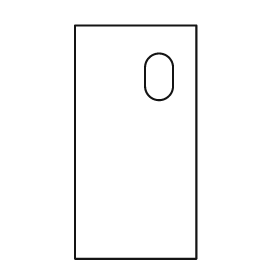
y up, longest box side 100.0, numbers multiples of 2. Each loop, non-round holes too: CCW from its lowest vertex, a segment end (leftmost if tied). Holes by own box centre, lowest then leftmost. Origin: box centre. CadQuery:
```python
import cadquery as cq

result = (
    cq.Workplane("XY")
    .moveTo(-26.0, -50.0)
    .lineTo(26.0, -50.0)
    .lineTo(26.0, 50.0)
    .lineTo(-26.0, 50.0)
    .close()
    .moveTo(4.0, 24.0)
    .threePointArc((10.0, 18.0), (16.0, 24.0))
    .lineTo(16.0, 32.0)
    .threePointArc((10.0, 38.0), (4.0, 32.0))
    .close()
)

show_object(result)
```